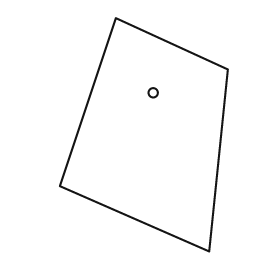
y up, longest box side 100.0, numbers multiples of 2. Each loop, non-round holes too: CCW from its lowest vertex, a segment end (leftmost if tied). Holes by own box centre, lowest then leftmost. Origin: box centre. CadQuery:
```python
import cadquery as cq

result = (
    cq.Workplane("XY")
    .moveTo(28.0, -50.0)
    .lineTo(36.0, 28.0)
    .lineTo(-12.0, 50.0)
    .lineTo(-36.0, -22.0)
    .close()
    .moveTo(4.0, 18.0)
    .circle(2.0)
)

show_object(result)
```